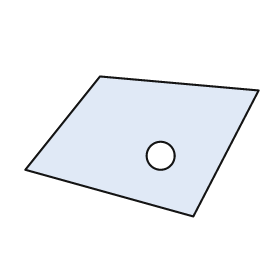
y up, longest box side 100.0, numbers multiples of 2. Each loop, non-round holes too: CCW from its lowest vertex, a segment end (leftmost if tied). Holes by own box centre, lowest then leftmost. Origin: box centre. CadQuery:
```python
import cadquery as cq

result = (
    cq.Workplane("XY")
    .moveTo(22.0, -30.0)
    .lineTo(50.0, 24.0)
    .lineTo(-18.0, 30.0)
    .lineTo(-50.0, -10.0)
    .close()
    .moveTo(8.0, -4.0)
    .circle(6.0)
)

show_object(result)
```